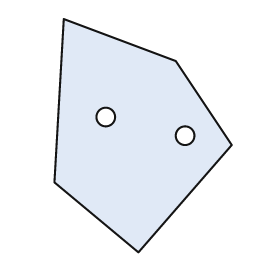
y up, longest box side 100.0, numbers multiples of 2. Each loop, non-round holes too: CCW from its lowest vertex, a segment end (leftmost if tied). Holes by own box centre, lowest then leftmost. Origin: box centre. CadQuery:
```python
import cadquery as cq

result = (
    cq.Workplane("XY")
    .moveTo(-2.0, -50.0)
    .lineTo(38.0, -4.0)
    .lineTo(14.0, 32.0)
    .lineTo(-34.0, 50.0)
    .lineTo(-38.0, -20.0)
    .close()
    .moveTo(18.0, 0.0)
    .circle(4.0)
    .moveTo(-16.0, 8.0)
    .circle(4.0)
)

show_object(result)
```